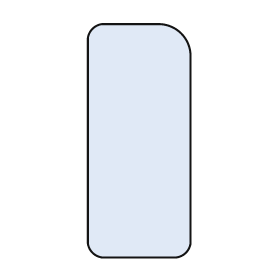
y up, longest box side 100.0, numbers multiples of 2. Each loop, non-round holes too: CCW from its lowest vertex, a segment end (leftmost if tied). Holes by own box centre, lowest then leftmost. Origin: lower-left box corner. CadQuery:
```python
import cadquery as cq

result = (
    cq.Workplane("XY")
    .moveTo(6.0, 0.0)
    .lineTo(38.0, 0.0)
    .threePointArc((42.0, 2.0), (44.0, 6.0))
    .lineTo(44.0, 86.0)
    .threePointArc((40.0, 96.0), (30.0, 100.0))
    .lineTo(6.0, 100.0)
    .threePointArc((2.0, 98.0), (0.0, 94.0))
    .lineTo(0.0, 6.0)
    .threePointArc((2.0, 2.0), (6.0, 0.0))
    .close()
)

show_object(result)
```